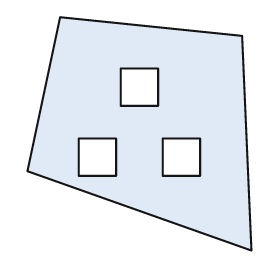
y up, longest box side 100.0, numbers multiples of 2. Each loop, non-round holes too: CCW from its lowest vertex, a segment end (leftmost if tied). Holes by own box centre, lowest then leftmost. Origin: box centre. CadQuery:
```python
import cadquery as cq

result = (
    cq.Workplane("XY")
    .moveTo(48.0, -50.0)
    .lineTo(44.0, 42.0)
    .lineTo(-34.0, 50.0)
    .lineTo(-48.0, -16.0)
    .close()
    .moveTo(-26.0, -18.0)
    .lineTo(-10.0, -18.0)
    .lineTo(-10.0, -2.0)
    .lineTo(-26.0, -2.0)
    .close()
    .moveTo(10.0, -18.0)
    .lineTo(26.0, -18.0)
    .lineTo(26.0, -2.0)
    .lineTo(10.0, -2.0)
    .close()
    .moveTo(-8.0, 12.0)
    .lineTo(8.0, 12.0)
    .lineTo(8.0, 28.0)
    .lineTo(-8.0, 28.0)
    .close()
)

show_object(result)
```